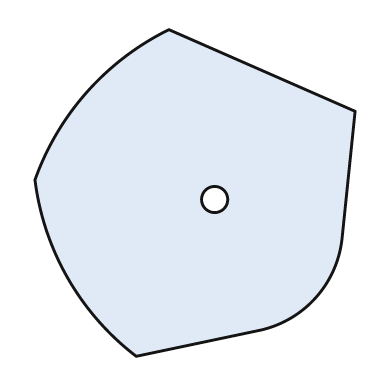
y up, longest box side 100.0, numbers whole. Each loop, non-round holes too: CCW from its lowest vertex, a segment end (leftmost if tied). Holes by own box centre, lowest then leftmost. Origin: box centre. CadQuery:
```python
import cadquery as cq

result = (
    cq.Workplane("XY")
    .moveTo(-18.0, -50.0)
    .lineTo(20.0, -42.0)
    .threePointArc((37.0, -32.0), (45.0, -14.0))
    .lineTo(49.0, 25.0)
    .lineTo(-8.0, 50.0)
    .threePointArc((-33.0, 31.0), (-49.0, 4.0))
    .threePointArc((-39.0, -26.0), (-18.0, -50.0))
    .close()
    .moveTo(6.0, -2.0)
    .circle(4.0)
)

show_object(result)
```